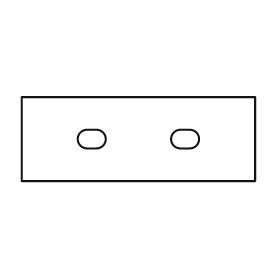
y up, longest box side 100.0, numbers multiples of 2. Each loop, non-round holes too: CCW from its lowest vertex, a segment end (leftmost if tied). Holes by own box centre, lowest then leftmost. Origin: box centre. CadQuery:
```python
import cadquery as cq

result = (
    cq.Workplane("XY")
    .moveTo(-50.0, -18.0)
    .lineTo(50.0, -18.0)
    .lineTo(50.0, 18.0)
    .lineTo(-50.0, 18.0)
    .close()
    .moveTo(-22.0, -4.0)
    .lineTo(-18.0, -4.0)
    .threePointArc((-14.0, 0.0), (-18.0, 4.0))
    .lineTo(-22.0, 4.0)
    .threePointArc((-26.0, 0.0), (-22.0, -4.0))
    .close()
    .moveTo(18.0, -4.0)
    .lineTo(22.0, -4.0)
    .threePointArc((26.0, 0.0), (22.0, 4.0))
    .lineTo(18.0, 4.0)
    .threePointArc((14.0, 0.0), (18.0, -4.0))
    .close()
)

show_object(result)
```